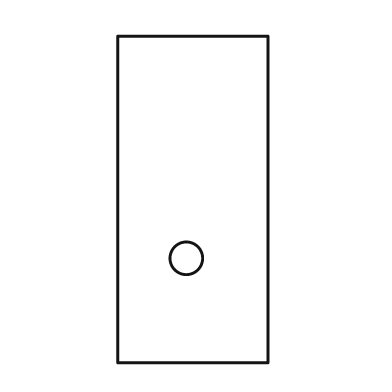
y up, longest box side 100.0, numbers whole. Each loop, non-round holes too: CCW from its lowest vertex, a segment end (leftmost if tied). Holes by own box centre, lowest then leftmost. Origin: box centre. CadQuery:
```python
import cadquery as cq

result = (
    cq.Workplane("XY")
    .moveTo(-23.0, -50.0)
    .lineTo(23.0, -50.0)
    .lineTo(23.0, 50.0)
    .lineTo(-23.0, 50.0)
    .close()
    .moveTo(-2.0, -18.0)
    .circle(5.0)
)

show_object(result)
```